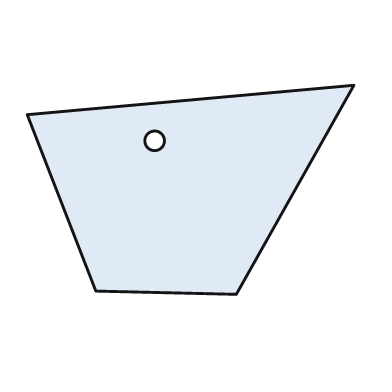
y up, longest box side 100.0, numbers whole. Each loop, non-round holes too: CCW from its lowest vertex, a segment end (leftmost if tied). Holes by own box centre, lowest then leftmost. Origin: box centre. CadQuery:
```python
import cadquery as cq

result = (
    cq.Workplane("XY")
    .moveTo(14.0, -32.0)
    .lineTo(50.0, 32.0)
    .lineTo(-50.0, 23.0)
    .lineTo(-29.0, -31.0)
    .close()
    .moveTo(-11.0, 15.0)
    .circle(3.0)
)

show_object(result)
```